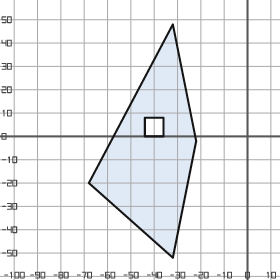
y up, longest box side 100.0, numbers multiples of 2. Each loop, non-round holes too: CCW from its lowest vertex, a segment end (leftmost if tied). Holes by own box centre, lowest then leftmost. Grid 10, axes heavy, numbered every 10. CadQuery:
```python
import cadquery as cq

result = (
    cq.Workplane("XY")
    .moveTo(-32.0, -52.0)
    .lineTo(-22.0, -2.0)
    .lineTo(-32.0, 48.0)
    .lineTo(-68.0, -20.0)
    .close()
    .moveTo(-44.0, 0.0)
    .lineTo(-36.0, 0.0)
    .lineTo(-36.0, 8.0)
    .lineTo(-44.0, 8.0)
    .close()
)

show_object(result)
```